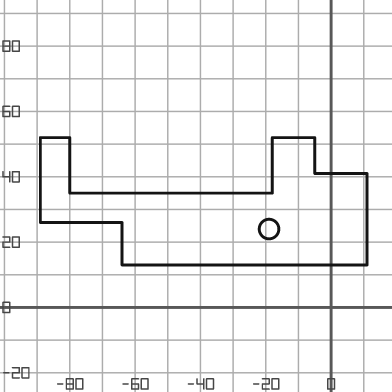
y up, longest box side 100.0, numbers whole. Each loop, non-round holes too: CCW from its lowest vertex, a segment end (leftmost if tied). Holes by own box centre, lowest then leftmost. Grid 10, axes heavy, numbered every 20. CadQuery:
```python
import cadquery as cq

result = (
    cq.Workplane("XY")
    .moveTo(-64.0, 13.0)
    .lineTo(11.0, 13.0)
    .lineTo(11.0, 41.0)
    .lineTo(-5.0, 41.0)
    .lineTo(-5.0, 52.0)
    .lineTo(-18.0, 52.0)
    .lineTo(-18.0, 35.0)
    .lineTo(-80.0, 35.0)
    .lineTo(-80.0, 52.0)
    .lineTo(-89.0, 52.0)
    .lineTo(-89.0, 26.0)
    .lineTo(-64.0, 26.0)
    .close()
    .moveTo(-19.0, 24.0)
    .circle(3.0)
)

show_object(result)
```